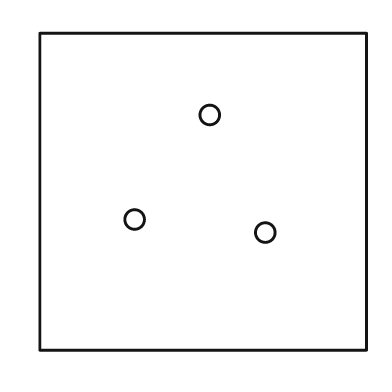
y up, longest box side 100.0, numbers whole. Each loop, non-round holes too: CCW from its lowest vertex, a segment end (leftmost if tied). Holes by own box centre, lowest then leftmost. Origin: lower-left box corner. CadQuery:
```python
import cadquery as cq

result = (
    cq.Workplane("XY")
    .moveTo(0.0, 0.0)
    .lineTo(100.0, 0.0)
    .lineTo(100.0, 97.0)
    .lineTo(0.0, 97.0)
    .close()
    .moveTo(69.0, 36.0)
    .circle(3.0)
    .moveTo(29.0, 40.0)
    .circle(3.0)
    .moveTo(52.0, 72.0)
    .circle(3.0)
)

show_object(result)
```